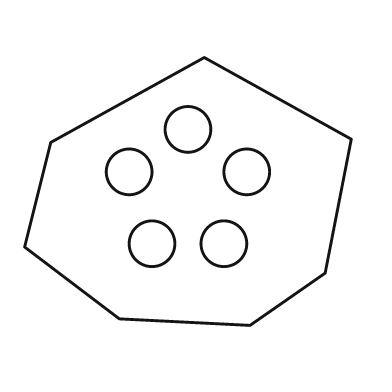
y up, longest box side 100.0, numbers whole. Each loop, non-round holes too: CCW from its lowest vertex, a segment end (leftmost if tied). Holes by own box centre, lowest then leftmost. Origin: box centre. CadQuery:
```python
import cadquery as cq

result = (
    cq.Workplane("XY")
    .moveTo(19.0, -41.0)
    .lineTo(42.0, -25.0)
    .lineTo(50.0, 16.0)
    .lineTo(5.0, 41.0)
    .lineTo(-42.0, 15.0)
    .lineTo(-50.0, -17.0)
    .lineTo(-21.0, -39.0)
    .close()
    .moveTo(-11.0, -16.0)
    .circle(7.0)
    .moveTo(11.0, -16.0)
    .circle(7.0)
    .moveTo(-18.0, 6.0)
    .circle(7.0)
    .moveTo(18.0, 6.0)
    .circle(7.0)
    .moveTo(0.0, 19.0)
    .circle(7.0)
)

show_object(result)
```